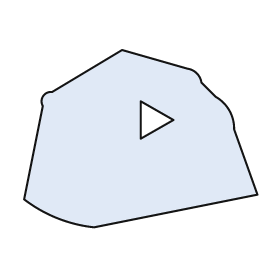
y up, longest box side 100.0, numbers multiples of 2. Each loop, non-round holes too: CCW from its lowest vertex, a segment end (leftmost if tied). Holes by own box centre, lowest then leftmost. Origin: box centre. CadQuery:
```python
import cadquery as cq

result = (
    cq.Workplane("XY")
    .moveTo(-20.0, -38.0)
    .lineTo(50.0, -24.0)
    .lineTo(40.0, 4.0)
    .threePointArc((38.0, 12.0), (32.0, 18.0))
    .lineTo(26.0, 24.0)
    .threePointArc((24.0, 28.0), (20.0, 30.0))
    .lineTo(-8.0, 38.0)
    .lineTo(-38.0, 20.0)
    .threePointArc((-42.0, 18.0), (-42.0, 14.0))
    .lineTo(-50.0, -26.0)
    .threePointArc((-36.0, -34.0), (-20.0, -38.0))
    .close()
    .moveTo(0.0, 0.0)
    .lineTo(14.0, 8.0)
    .lineTo(0.0, 16.0)
    .close()
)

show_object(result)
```